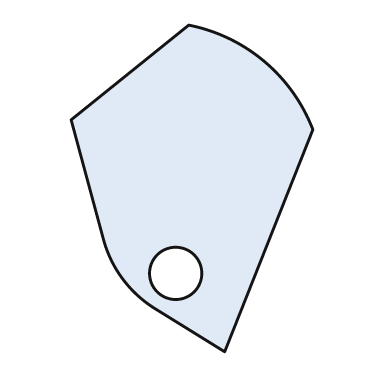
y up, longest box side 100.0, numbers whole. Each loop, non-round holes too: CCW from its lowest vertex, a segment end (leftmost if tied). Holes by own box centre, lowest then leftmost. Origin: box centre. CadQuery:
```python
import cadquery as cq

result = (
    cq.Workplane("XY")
    .moveTo(10.0, -50.0)
    .lineTo(37.0, 18.0)
    .threePointArc((22.0, 39.0), (-1.0, 50.0))
    .lineTo(-37.0, 21.0)
    .lineTo(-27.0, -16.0)
    .threePointArc((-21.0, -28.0), (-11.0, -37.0))
    .close()
    .moveTo(-5.0, -26.0)
    .circle(8.0)
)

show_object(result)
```